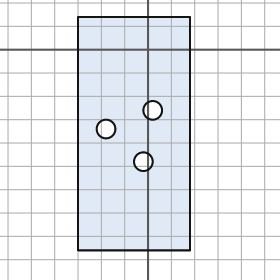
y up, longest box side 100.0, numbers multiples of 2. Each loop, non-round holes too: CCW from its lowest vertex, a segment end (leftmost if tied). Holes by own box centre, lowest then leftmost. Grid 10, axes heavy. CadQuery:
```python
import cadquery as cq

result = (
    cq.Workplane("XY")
    .moveTo(-30.0, -86.0)
    .lineTo(18.0, -86.0)
    .lineTo(18.0, 14.0)
    .lineTo(-30.0, 14.0)
    .close()
    .moveTo(-2.0, -48.0)
    .circle(4.0)
    .moveTo(-18.0, -34.0)
    .circle(4.0)
    .moveTo(2.0, -26.0)
    .circle(4.0)
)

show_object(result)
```